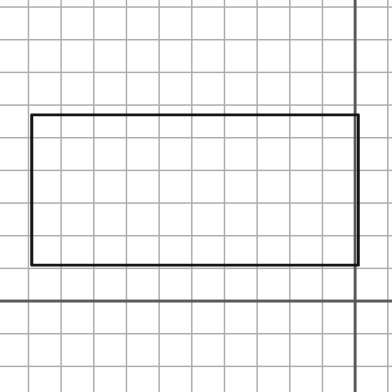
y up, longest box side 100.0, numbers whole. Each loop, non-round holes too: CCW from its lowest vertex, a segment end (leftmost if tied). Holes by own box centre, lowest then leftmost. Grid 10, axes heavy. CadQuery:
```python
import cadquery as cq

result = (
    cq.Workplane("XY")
    .moveTo(-99.0, 11.0)
    .lineTo(1.0, 11.0)
    .lineTo(1.0, 57.0)
    .lineTo(-99.0, 57.0)
    .close()
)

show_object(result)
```